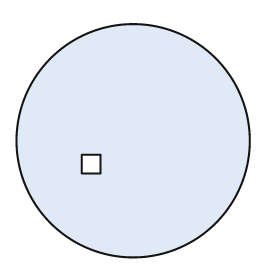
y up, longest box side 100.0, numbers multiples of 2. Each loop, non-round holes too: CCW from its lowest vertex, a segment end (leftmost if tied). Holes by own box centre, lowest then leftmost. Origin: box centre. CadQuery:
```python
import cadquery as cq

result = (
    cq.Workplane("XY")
    .moveTo(0.0, 0.0)
    .circle(50.0)
    .moveTo(-22.0, -14.0)
    .lineTo(-14.0, -14.0)
    .lineTo(-14.0, -6.0)
    .lineTo(-22.0, -6.0)
    .close()
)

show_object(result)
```